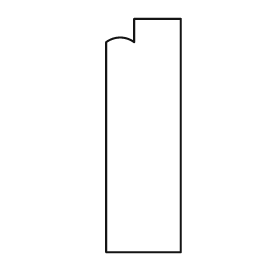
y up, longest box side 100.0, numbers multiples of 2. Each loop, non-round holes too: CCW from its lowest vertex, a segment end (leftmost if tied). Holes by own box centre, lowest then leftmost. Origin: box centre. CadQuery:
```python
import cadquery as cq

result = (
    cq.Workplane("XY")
    .moveTo(-16.0, -50.0)
    .lineTo(16.0, -50.0)
    .lineTo(16.0, 50.0)
    .lineTo(-4.0, 50.0)
    .lineTo(-4.0, 40.0)
    .threePointArc((-10.0, 42.0), (-16.0, 40.0))
    .close()
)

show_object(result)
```